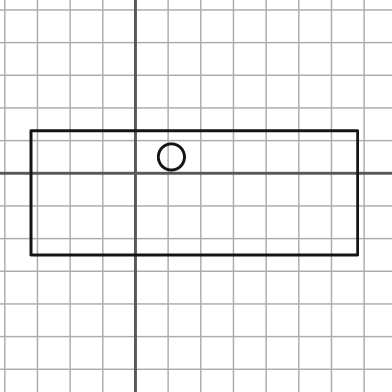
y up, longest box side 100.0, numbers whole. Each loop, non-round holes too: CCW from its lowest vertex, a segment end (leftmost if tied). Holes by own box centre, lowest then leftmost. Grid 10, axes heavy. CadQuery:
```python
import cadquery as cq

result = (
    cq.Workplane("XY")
    .moveTo(-32.0, -25.0)
    .lineTo(68.0, -25.0)
    .lineTo(68.0, 13.0)
    .lineTo(-32.0, 13.0)
    .close()
    .moveTo(11.0, 5.0)
    .circle(4.0)
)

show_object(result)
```